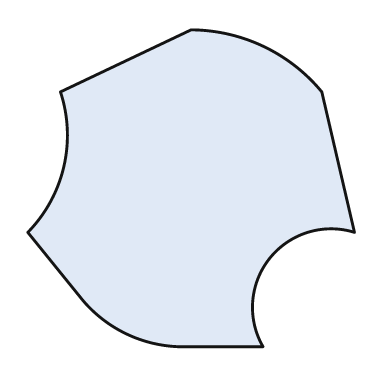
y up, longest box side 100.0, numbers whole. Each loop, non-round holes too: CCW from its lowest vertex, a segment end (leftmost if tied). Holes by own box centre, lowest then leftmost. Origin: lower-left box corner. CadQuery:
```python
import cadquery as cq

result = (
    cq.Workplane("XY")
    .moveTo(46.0, 0.0)
    .lineTo(72.0, 0.0)
    .threePointArc((74.0, 27.0), (100.0, 35.0))
    .lineTo(90.0, 78.0)
    .threePointArc((72.0, 92.0), (50.0, 97.0))
    .lineTo(10.0, 78.0)
    .threePointArc((11.0, 55.0), (0.0, 35.0))
    .lineTo(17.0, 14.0)
    .threePointArc((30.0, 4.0), (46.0, 0.0))
    .close()
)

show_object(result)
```